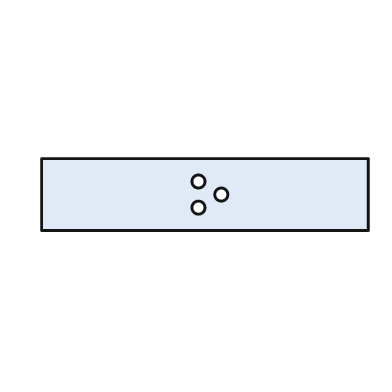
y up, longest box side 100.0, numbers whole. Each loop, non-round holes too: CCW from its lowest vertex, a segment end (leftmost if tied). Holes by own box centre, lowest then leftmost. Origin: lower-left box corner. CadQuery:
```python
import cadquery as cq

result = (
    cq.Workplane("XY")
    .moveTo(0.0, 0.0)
    .lineTo(100.0, 0.0)
    .lineTo(100.0, 22.0)
    .lineTo(0.0, 22.0)
    .close()
    .moveTo(48.0, 7.0)
    .circle(2.0)
    .moveTo(55.0, 11.0)
    .circle(2.0)
    .moveTo(48.0, 15.0)
    .circle(2.0)
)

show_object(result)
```